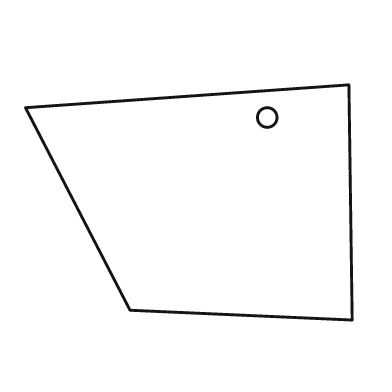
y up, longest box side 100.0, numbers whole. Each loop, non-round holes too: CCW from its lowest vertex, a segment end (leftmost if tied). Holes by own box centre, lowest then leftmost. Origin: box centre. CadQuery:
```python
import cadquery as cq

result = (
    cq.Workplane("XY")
    .moveTo(50.0, -36.0)
    .lineTo(49.0, 36.0)
    .lineTo(-50.0, 29.0)
    .lineTo(-18.0, -33.0)
    .close()
    .moveTo(24.0, 26.0)
    .circle(3.0)
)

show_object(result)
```